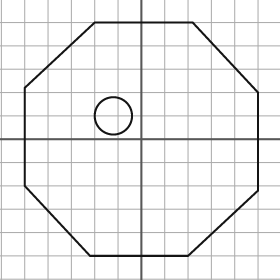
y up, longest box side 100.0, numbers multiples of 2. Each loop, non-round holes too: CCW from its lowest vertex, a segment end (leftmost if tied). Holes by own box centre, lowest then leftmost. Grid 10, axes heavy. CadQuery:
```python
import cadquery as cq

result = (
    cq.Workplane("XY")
    .moveTo(-22.0, -50.0)
    .lineTo(20.0, -50.0)
    .lineTo(50.0, -22.0)
    .lineTo(50.0, 20.0)
    .lineTo(22.0, 50.0)
    .lineTo(-20.0, 50.0)
    .lineTo(-50.0, 22.0)
    .lineTo(-50.0, -20.0)
    .close()
    .moveTo(-12.0, 10.0)
    .circle(8.0)
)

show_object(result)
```